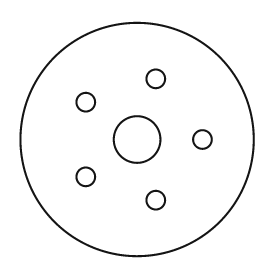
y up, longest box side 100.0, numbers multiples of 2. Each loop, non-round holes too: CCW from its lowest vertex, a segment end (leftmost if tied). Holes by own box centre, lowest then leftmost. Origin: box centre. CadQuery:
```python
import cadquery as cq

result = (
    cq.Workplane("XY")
    .moveTo(0.0, 0.0)
    .circle(50.0)
    .moveTo(8.0, -26.0)
    .circle(4.0)
    .moveTo(-22.0, -16.0)
    .circle(4.0)
    .moveTo(0.0, 0.0)
    .circle(10.0)
    .moveTo(28.0, 0.0)
    .circle(4.0)
    .moveTo(-22.0, 16.0)
    .circle(4.0)
    .moveTo(8.0, 26.0)
    .circle(4.0)
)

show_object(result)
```